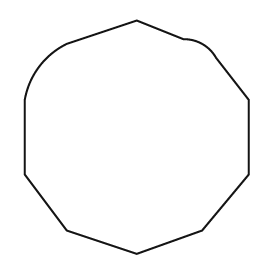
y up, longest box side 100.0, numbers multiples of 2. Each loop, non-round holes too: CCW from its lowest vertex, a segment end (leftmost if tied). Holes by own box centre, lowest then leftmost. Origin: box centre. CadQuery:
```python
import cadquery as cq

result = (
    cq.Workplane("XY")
    .moveTo(0.0, -50.0)
    .lineTo(28.0, -40.0)
    .lineTo(48.0, -16.0)
    .lineTo(48.0, 16.0)
    .lineTo(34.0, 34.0)
    .threePointArc((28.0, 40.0), (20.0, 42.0))
    .lineTo(0.0, 50.0)
    .lineTo(-30.0, 40.0)
    .threePointArc((-42.0, 30.0), (-48.0, 16.0))
    .lineTo(-48.0, -16.0)
    .lineTo(-30.0, -40.0)
    .close()
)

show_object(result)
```